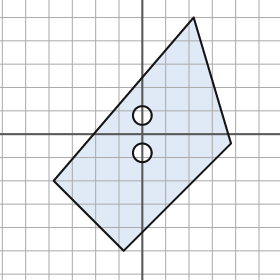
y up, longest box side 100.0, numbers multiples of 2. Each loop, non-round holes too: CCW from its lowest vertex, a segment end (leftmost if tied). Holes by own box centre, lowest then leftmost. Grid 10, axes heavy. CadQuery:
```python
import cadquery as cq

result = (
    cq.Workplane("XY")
    .moveTo(-8.0, -50.0)
    .lineTo(38.0, -4.0)
    .lineTo(22.0, 50.0)
    .lineTo(-38.0, -20.0)
    .close()
    .moveTo(0.0, -8.0)
    .circle(4.0)
    .moveTo(0.0, 8.0)
    .circle(4.0)
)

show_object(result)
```